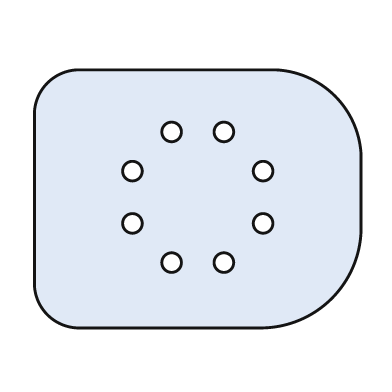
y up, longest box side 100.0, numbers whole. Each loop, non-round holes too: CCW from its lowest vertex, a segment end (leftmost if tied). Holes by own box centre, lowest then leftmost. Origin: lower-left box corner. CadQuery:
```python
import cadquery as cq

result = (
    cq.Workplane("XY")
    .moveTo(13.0, 0.0)
    .lineTo(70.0, 0.0)
    .threePointArc((91.0, 9.0), (100.0, 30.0))
    .lineTo(100.0, 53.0)
    .threePointArc((92.0, 71.0), (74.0, 79.0))
    .lineTo(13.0, 79.0)
    .threePointArc((4.0, 75.0), (0.0, 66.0))
    .lineTo(0.0, 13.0)
    .threePointArc((4.0, 4.0), (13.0, 0.0))
    .close()
    .moveTo(42.0, 20.0)
    .circle(3.0)
    .moveTo(58.0, 20.0)
    .circle(3.0)
    .moveTo(30.0, 32.0)
    .circle(3.0)
    .moveTo(70.0, 32.0)
    .circle(3.0)
    .moveTo(30.0, 48.0)
    .circle(3.0)
    .moveTo(70.0, 48.0)
    .circle(3.0)
    .moveTo(42.0, 60.0)
    .circle(3.0)
    .moveTo(58.0, 60.0)
    .circle(3.0)
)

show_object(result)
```